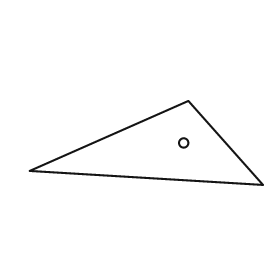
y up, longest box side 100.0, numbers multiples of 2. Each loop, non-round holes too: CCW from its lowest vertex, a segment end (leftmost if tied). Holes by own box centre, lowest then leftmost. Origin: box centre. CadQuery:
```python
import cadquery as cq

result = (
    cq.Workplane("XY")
    .moveTo(50.0, -18.0)
    .lineTo(18.0, 18.0)
    .lineTo(-50.0, -12.0)
    .close()
    .moveTo(16.0, 0.0)
    .circle(2.0)
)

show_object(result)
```